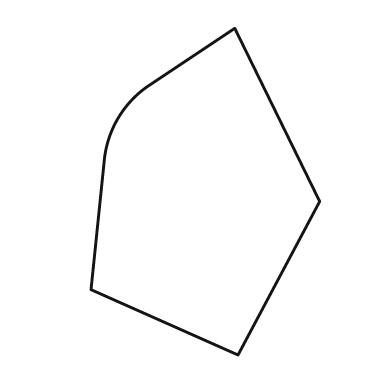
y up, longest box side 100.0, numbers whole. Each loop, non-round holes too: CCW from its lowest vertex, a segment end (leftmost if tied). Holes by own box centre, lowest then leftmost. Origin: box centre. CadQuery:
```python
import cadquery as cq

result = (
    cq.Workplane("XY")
    .moveTo(10.0, -50.0)
    .lineTo(35.0, -3.0)
    .lineTo(9.0, 50.0)
    .lineTo(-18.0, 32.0)
    .threePointArc((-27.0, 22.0), (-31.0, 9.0))
    .lineTo(-35.0, -30.0)
    .close()
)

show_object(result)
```